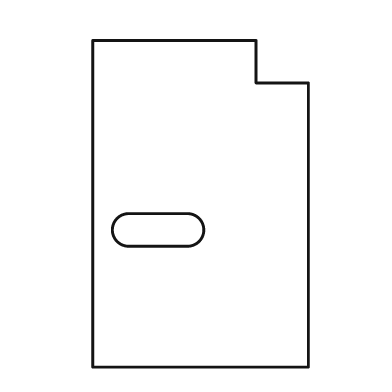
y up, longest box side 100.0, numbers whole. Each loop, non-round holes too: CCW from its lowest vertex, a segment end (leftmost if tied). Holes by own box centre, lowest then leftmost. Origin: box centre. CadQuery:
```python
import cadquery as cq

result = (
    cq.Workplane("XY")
    .moveTo(-33.0, -50.0)
    .lineTo(33.0, -50.0)
    .lineTo(33.0, 37.0)
    .lineTo(17.0, 37.0)
    .lineTo(17.0, 50.0)
    .lineTo(-33.0, 50.0)
    .close()
    .moveTo(-22.0, -13.0)
    .lineTo(-4.0, -13.0)
    .threePointArc((1.0, -8.0), (-4.0, -3.0))
    .lineTo(-22.0, -3.0)
    .threePointArc((-27.0, -8.0), (-22.0, -13.0))
    .close()
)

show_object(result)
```